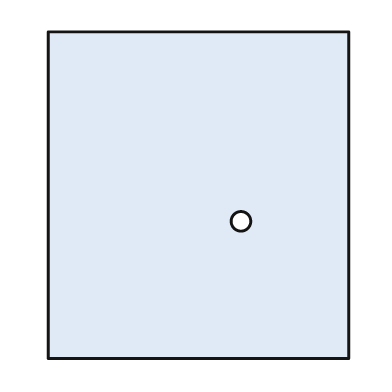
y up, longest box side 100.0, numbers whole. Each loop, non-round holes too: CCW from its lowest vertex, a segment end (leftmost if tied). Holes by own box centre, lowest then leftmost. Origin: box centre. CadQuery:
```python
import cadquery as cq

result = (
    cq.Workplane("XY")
    .moveTo(-46.0, -50.0)
    .lineTo(46.0, -50.0)
    .lineTo(46.0, 50.0)
    .lineTo(-46.0, 50.0)
    .close()
    .moveTo(13.0, -8.0)
    .circle(3.0)
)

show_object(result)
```